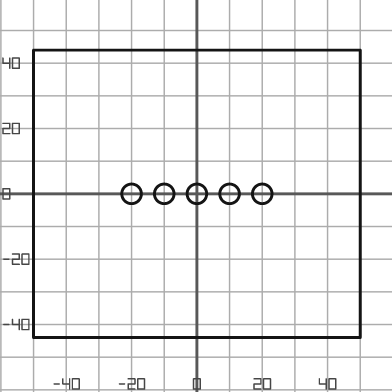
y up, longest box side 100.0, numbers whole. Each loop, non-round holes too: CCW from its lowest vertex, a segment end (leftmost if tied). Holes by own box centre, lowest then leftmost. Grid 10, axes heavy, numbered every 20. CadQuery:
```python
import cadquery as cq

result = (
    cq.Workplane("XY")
    .moveTo(-50.0, -44.0)
    .lineTo(50.0, -44.0)
    .lineTo(50.0, 44.0)
    .lineTo(-50.0, 44.0)
    .close()
    .moveTo(-20.0, 0.0)
    .circle(3.0)
    .moveTo(-10.0, 0.0)
    .circle(3.0)
    .moveTo(0.0, 0.0)
    .circle(3.0)
    .moveTo(10.0, 0.0)
    .circle(3.0)
    .moveTo(20.0, 0.0)
    .circle(3.0)
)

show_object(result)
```